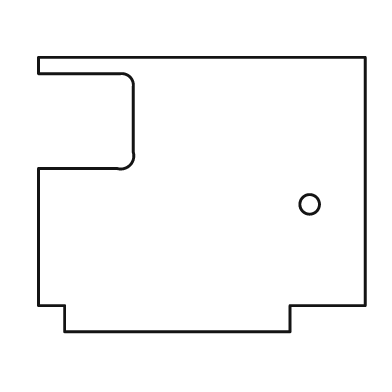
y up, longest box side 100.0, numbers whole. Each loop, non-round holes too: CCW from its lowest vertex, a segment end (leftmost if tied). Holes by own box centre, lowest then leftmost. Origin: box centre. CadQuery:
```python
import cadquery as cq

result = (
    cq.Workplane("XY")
    .moveTo(-42.0, -42.0)
    .lineTo(27.0, -42.0)
    .lineTo(27.0, -34.0)
    .lineTo(50.0, -34.0)
    .lineTo(50.0, 42.0)
    .lineTo(-50.0, 42.0)
    .lineTo(-50.0, 37.0)
    .lineTo(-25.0, 37.0)
    .threePointArc((-22.0, 36.0), (-21.0, 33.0))
    .lineTo(-21.0, 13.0)
    .threePointArc((-22.0, 9.0), (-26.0, 8.0))
    .lineTo(-50.0, 8.0)
    .lineTo(-50.0, -34.0)
    .lineTo(-42.0, -34.0)
    .close()
    .moveTo(33.0, -3.0)
    .circle(3.0)
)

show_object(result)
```